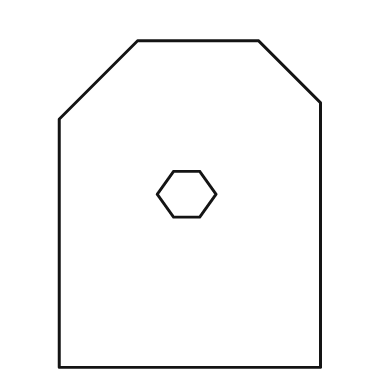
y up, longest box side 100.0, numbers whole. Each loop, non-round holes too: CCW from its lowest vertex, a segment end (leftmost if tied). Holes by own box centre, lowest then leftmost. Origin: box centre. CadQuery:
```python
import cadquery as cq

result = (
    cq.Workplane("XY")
    .moveTo(-40.0, -50.0)
    .lineTo(40.0, -50.0)
    .lineTo(40.0, 31.0)
    .lineTo(21.0, 50.0)
    .lineTo(-16.0, 50.0)
    .lineTo(-40.0, 26.0)
    .close()
    .moveTo(-5.0, -4.0)
    .lineTo(3.0, -4.0)
    .lineTo(8.0, 3.0)
    .lineTo(3.0, 10.0)
    .lineTo(-5.0, 10.0)
    .lineTo(-10.0, 3.0)
    .close()
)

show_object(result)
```